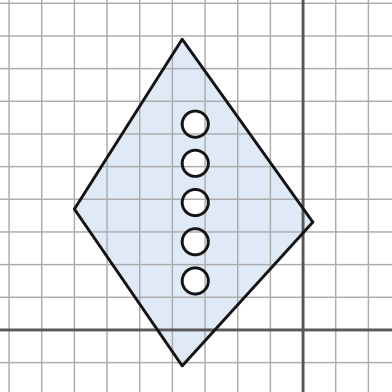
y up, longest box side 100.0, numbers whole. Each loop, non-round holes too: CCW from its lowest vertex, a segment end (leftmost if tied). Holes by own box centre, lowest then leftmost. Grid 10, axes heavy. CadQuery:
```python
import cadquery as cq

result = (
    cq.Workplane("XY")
    .moveTo(-37.0, -11.0)
    .lineTo(3.0, 33.0)
    .lineTo(-37.0, 89.0)
    .lineTo(-70.0, 37.0)
    .close()
    .moveTo(-33.0, 15.0)
    .circle(4.0)
    .moveTo(-33.0, 27.0)
    .circle(4.0)
    .moveTo(-33.0, 39.0)
    .circle(4.0)
    .moveTo(-33.0, 51.0)
    .circle(4.0)
    .moveTo(-33.0, 63.0)
    .circle(4.0)
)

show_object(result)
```